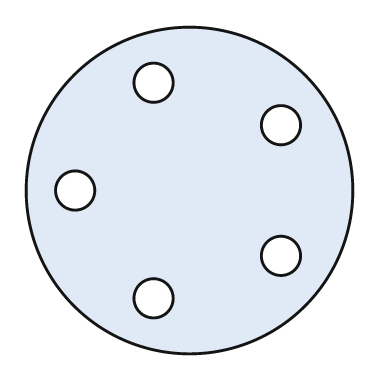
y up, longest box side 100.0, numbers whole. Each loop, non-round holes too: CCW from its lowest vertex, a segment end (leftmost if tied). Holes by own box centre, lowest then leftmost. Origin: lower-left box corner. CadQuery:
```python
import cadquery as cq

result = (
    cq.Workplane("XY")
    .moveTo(50.0, 50.0)
    .circle(50.0)
    .moveTo(39.0, 17.0)
    .circle(6.0)
    .moveTo(78.0, 30.0)
    .circle(6.0)
    .moveTo(15.0, 50.0)
    .circle(6.0)
    .moveTo(78.0, 70.0)
    .circle(6.0)
    .moveTo(39.0, 83.0)
    .circle(6.0)
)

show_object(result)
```